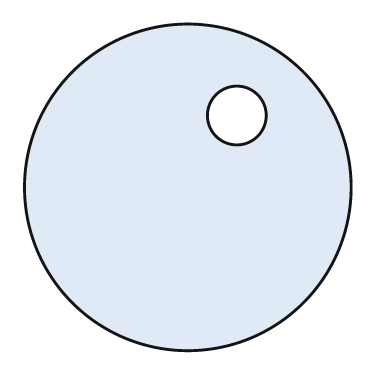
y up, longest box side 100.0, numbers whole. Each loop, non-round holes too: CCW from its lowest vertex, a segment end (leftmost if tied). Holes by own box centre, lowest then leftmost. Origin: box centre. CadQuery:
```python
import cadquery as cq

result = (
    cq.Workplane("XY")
    .moveTo(0.0, 0.0)
    .circle(50.0)
    .moveTo(15.0, 22.0)
    .circle(9.0)
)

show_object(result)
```